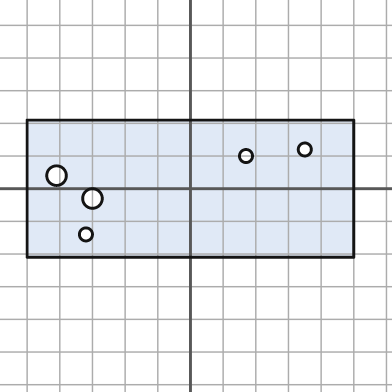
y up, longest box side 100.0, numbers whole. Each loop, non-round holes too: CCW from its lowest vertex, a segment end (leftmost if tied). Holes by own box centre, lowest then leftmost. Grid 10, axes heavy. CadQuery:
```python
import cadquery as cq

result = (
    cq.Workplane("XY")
    .moveTo(-50.0, -21.0)
    .lineTo(50.0, -21.0)
    .lineTo(50.0, 21.0)
    .lineTo(-50.0, 21.0)
    .close()
    .moveTo(-32.0, -14.0)
    .circle(2.0)
    .moveTo(-30.0, -3.0)
    .circle(3.0)
    .moveTo(-41.0, 4.0)
    .circle(3.0)
    .moveTo(17.0, 10.0)
    .circle(2.0)
    .moveTo(35.0, 12.0)
    .circle(2.0)
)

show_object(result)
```